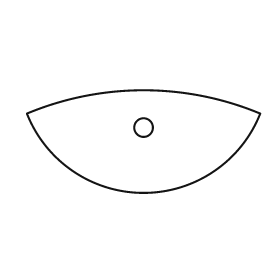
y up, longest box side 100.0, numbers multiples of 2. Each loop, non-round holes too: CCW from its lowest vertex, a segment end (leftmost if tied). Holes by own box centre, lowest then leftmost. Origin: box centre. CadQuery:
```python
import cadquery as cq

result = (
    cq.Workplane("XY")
    .moveTo(-50.0, 12.0)
    .threePointArc((0.0, -22.0), (50.0, 12.0))
    .threePointArc((0.0, 22.0), (-50.0, 12.0))
    .close()
    .moveTo(0.0, 6.0)
    .circle(4.0)
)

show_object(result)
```